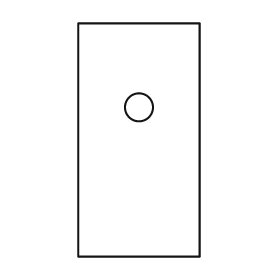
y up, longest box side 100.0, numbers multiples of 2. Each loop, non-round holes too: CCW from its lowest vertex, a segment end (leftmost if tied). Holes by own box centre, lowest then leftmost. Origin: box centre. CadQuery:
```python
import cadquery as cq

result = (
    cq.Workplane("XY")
    .moveTo(-26.0, -50.0)
    .lineTo(26.0, -50.0)
    .lineTo(26.0, 50.0)
    .lineTo(-26.0, 50.0)
    .close()
    .moveTo(0.0, 14.0)
    .circle(6.0)
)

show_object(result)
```